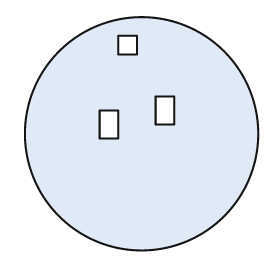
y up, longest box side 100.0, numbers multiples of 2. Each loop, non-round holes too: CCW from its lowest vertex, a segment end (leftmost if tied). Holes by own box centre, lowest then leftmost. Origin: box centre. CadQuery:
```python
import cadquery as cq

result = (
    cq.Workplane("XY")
    .moveTo(0.0, 0.0)
    .circle(50.0)
    .moveTo(-18.0, -2.0)
    .lineTo(-10.0, -2.0)
    .lineTo(-10.0, 10.0)
    .lineTo(-18.0, 10.0)
    .close()
    .moveTo(6.0, 4.0)
    .lineTo(14.0, 4.0)
    .lineTo(14.0, 16.0)
    .lineTo(6.0, 16.0)
    .close()
    .moveTo(-10.0, 34.0)
    .lineTo(-2.0, 34.0)
    .lineTo(-2.0, 42.0)
    .lineTo(-10.0, 42.0)
    .close()
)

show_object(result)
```